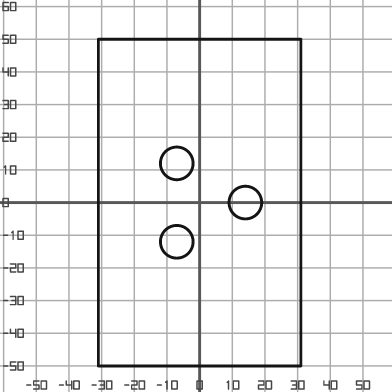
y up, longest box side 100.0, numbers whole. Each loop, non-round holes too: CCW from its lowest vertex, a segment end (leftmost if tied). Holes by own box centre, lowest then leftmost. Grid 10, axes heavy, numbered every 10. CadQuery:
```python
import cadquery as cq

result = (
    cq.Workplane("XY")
    .moveTo(-31.0, -50.0)
    .lineTo(31.0, -50.0)
    .lineTo(31.0, 50.0)
    .lineTo(-31.0, 50.0)
    .close()
    .moveTo(-7.0, -12.0)
    .circle(5.0)
    .moveTo(14.0, 0.0)
    .circle(5.0)
    .moveTo(-7.0, 12.0)
    .circle(5.0)
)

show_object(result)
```